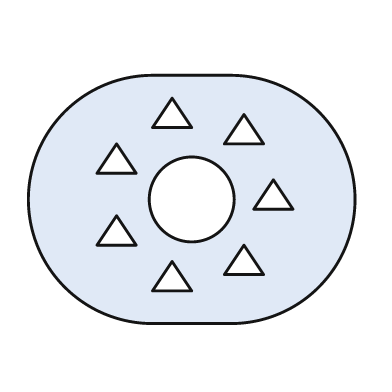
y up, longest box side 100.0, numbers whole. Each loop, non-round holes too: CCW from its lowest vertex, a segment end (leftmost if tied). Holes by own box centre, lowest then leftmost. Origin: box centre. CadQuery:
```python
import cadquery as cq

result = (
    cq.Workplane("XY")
    .moveTo(-12.0, -38.0)
    .lineTo(12.0, -38.0)
    .threePointArc((50.0, 0.0), (12.0, 38.0))
    .lineTo(-12.0, 38.0)
    .threePointArc((-50.0, 0.0), (-12.0, -38.0))
    .close()
    .moveTo(-12.0, -28.0)
    .lineTo(0.0, -28.0)
    .lineTo(-6.0, -19.0)
    .close()
    .moveTo(10.0, -23.0)
    .lineTo(22.0, -23.0)
    .lineTo(16.0, -14.0)
    .close()
    .moveTo(-29.0, -14.0)
    .lineTo(-17.0, -14.0)
    .lineTo(-23.0, -5.0)
    .close()
    .moveTo(0.0, 0.0)
    .circle(13.0)
    .moveTo(19.0, -3.0)
    .lineTo(31.0, -3.0)
    .lineTo(25.0, 6.0)
    .close()
    .moveTo(-29.0, 8.0)
    .lineTo(-17.0, 8.0)
    .lineTo(-23.0, 17.0)
    .close()
    .moveTo(10.0, 17.0)
    .lineTo(22.0, 17.0)
    .lineTo(16.0, 26.0)
    .close()
    .moveTo(-12.0, 22.0)
    .lineTo(0.0, 22.0)
    .lineTo(-6.0, 31.0)
    .close()
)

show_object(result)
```